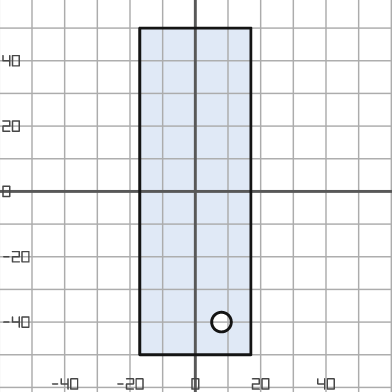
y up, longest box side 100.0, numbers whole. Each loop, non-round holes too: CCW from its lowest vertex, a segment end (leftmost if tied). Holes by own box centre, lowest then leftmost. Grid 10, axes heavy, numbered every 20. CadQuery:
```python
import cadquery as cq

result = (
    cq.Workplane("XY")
    .moveTo(-17.0, -50.0)
    .lineTo(17.0, -50.0)
    .lineTo(17.0, 50.0)
    .lineTo(-17.0, 50.0)
    .close()
    .moveTo(8.0, -40.0)
    .circle(3.0)
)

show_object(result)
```